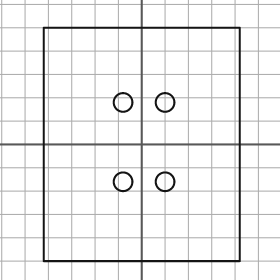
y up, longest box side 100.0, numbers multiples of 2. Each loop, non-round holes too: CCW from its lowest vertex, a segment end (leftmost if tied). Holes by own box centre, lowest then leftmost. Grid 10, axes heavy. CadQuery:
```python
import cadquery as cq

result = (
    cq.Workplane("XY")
    .moveTo(-42.0, -50.0)
    .lineTo(42.0, -50.0)
    .lineTo(42.0, 50.0)
    .lineTo(-42.0, 50.0)
    .close()
    .moveTo(-8.0, -16.0)
    .circle(4.0)
    .moveTo(10.0, -16.0)
    .circle(4.0)
    .moveTo(-8.0, 18.0)
    .circle(4.0)
    .moveTo(10.0, 18.0)
    .circle(4.0)
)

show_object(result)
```